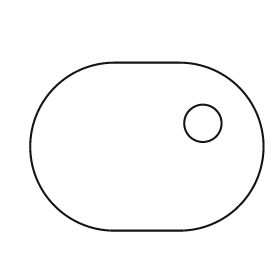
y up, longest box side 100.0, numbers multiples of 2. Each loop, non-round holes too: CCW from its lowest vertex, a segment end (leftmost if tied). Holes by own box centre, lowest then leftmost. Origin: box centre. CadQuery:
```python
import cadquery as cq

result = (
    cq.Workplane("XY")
    .moveTo(-14.0, -36.0)
    .lineTo(14.0, -36.0)
    .threePointArc((50.0, 0.0), (14.0, 36.0))
    .lineTo(-14.0, 36.0)
    .threePointArc((-50.0, 0.0), (-14.0, -36.0))
    .close()
    .moveTo(24.0, 10.0)
    .circle(8.0)
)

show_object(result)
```